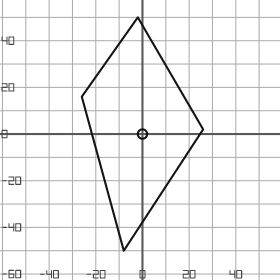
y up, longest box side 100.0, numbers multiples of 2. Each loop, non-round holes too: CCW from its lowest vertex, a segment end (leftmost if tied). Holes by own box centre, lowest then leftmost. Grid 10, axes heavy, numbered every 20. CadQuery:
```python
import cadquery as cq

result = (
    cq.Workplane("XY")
    .moveTo(-8.0, -50.0)
    .lineTo(26.0, 2.0)
    .lineTo(-2.0, 50.0)
    .lineTo(-26.0, 16.0)
    .close()
    .moveTo(0.0, 0.0)
    .circle(2.0)
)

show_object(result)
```